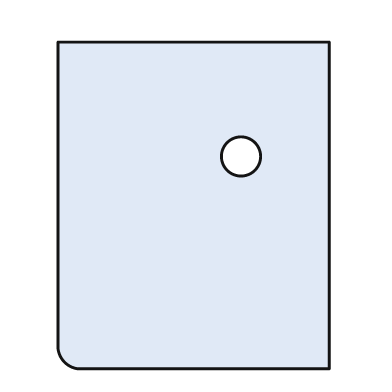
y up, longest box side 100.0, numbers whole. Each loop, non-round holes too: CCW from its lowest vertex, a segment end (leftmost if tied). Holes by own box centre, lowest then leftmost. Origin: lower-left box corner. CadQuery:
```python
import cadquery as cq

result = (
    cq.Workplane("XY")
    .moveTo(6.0, 0.0)
    .lineTo(83.0, 0.0)
    .lineTo(83.0, 100.0)
    .lineTo(0.0, 100.0)
    .lineTo(0.0, 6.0)
    .threePointArc((2.0, 2.0), (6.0, 0.0))
    .close()
    .moveTo(56.0, 65.0)
    .circle(6.0)
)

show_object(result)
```